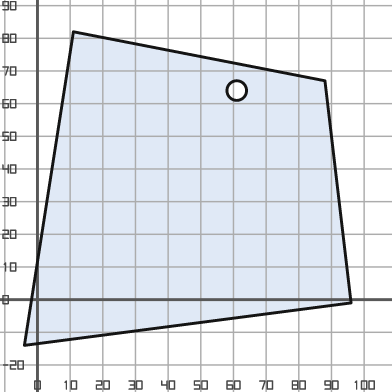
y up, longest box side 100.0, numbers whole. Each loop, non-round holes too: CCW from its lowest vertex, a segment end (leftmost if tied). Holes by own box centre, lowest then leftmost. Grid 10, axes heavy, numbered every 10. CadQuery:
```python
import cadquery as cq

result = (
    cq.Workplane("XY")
    .moveTo(-4.0, -14.0)
    .lineTo(96.0, -1.0)
    .lineTo(88.0, 67.0)
    .lineTo(11.0, 82.0)
    .close()
    .moveTo(61.0, 64.0)
    .circle(3.0)
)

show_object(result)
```